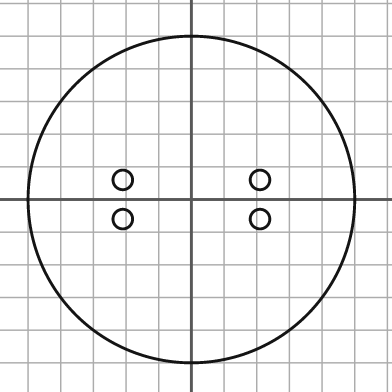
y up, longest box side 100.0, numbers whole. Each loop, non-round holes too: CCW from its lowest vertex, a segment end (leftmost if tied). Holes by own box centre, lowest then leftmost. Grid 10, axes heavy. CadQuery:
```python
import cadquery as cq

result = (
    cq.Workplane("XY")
    .moveTo(0.0, 0.0)
    .circle(50.0)
    .moveTo(-21.0, -6.0)
    .circle(3.0)
    .moveTo(21.0, -6.0)
    .circle(3.0)
    .moveTo(-21.0, 6.0)
    .circle(3.0)
    .moveTo(21.0, 6.0)
    .circle(3.0)
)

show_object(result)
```